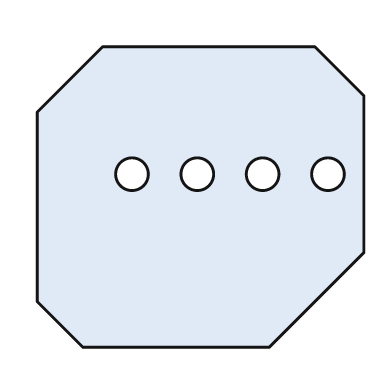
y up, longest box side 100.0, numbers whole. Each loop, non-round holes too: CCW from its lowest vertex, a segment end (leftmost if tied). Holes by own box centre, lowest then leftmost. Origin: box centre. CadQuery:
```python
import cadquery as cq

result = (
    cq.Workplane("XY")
    .moveTo(-36.0, -46.0)
    .lineTo(21.0, -46.0)
    .lineTo(50.0, -17.0)
    .lineTo(50.0, 31.0)
    .lineTo(35.0, 46.0)
    .lineTo(-30.0, 46.0)
    .lineTo(-50.0, 26.0)
    .lineTo(-50.0, -32.0)
    .close()
    .moveTo(-21.0, 7.0)
    .circle(5.0)
    .moveTo(-1.0, 7.0)
    .circle(5.0)
    .moveTo(19.0, 7.0)
    .circle(5.0)
    .moveTo(39.0, 7.0)
    .circle(5.0)
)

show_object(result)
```